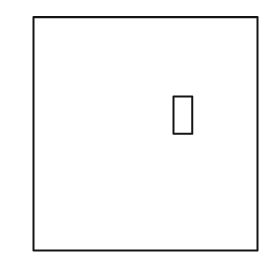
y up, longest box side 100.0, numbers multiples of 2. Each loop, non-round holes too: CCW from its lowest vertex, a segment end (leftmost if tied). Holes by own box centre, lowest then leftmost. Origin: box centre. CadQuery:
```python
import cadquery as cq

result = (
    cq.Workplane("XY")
    .moveTo(-48.0, -50.0)
    .lineTo(48.0, -50.0)
    .lineTo(48.0, 50.0)
    .lineTo(-48.0, 50.0)
    .close()
    .moveTo(12.0, 0.0)
    .lineTo(20.0, 0.0)
    .lineTo(20.0, 16.0)
    .lineTo(12.0, 16.0)
    .close()
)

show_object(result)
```